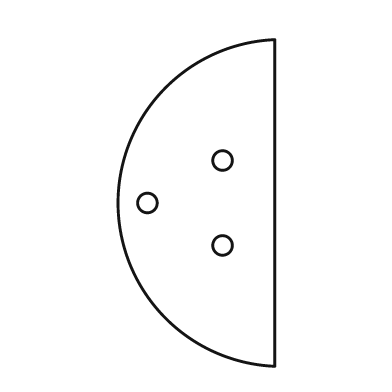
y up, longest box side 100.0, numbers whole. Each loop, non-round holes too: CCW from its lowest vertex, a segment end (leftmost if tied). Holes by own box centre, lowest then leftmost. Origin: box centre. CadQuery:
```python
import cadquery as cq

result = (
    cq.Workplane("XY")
    .moveTo(24.0, -50.0)
    .lineTo(24.0, 50.0)
    .threePointArc((-24.0, 0.0), (24.0, -50.0))
    .close()
    .moveTo(8.0, -13.0)
    .circle(3.0)
    .moveTo(-15.0, 0.0)
    .circle(3.0)
    .moveTo(8.0, 13.0)
    .circle(3.0)
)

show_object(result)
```